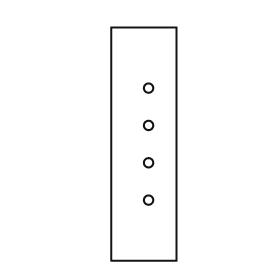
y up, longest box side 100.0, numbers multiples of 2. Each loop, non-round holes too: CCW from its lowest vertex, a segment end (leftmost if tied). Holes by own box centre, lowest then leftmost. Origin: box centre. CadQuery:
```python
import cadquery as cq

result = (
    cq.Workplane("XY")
    .moveTo(-14.0, -50.0)
    .lineTo(14.0, -50.0)
    .lineTo(14.0, 50.0)
    .lineTo(-14.0, 50.0)
    .close()
    .moveTo(2.0, -24.0)
    .circle(2.0)
    .moveTo(2.0, -8.0)
    .circle(2.0)
    .moveTo(2.0, 8.0)
    .circle(2.0)
    .moveTo(2.0, 24.0)
    .circle(2.0)
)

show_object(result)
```